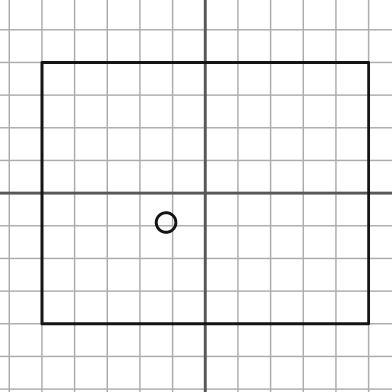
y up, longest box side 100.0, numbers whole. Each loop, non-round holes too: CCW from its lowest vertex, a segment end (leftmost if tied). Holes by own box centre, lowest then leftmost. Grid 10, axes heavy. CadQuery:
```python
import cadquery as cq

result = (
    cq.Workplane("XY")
    .moveTo(-50.0, -40.0)
    .lineTo(50.0, -40.0)
    .lineTo(50.0, 40.0)
    .lineTo(-50.0, 40.0)
    .close()
    .moveTo(-12.0, -9.0)
    .circle(3.0)
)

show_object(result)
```